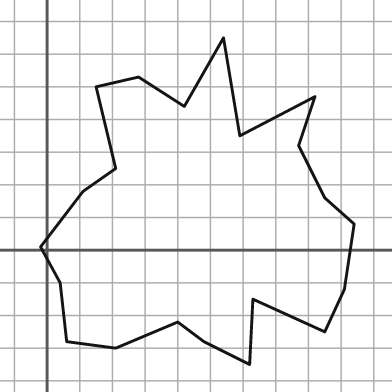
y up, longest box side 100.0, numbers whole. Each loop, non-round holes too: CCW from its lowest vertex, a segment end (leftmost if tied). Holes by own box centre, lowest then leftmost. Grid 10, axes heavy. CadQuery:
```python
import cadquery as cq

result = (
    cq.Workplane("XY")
    .moveTo(62.0, -35.0)
    .lineTo(63.0, -15.0)
    .lineTo(85.0, -25.0)
    .lineTo(91.0, -12.0)
    .lineTo(94.0, 8.0)
    .lineTo(85.0, 16.0)
    .lineTo(77.0, 32.0)
    .lineTo(82.0, 47.0)
    .lineTo(59.0, 35.0)
    .lineTo(54.0, 65.0)
    .lineTo(42.0, 44.0)
    .lineTo(28.0, 53.0)
    .lineTo(15.0, 50.0)
    .lineTo(21.0, 25.0)
    .lineTo(11.0, 18.0)
    .lineTo(-2.0, 1.0)
    .lineTo(4.0, -10.0)
    .lineTo(6.0, -28.0)
    .lineTo(21.0, -30.0)
    .lineTo(40.0, -22.0)
    .lineTo(48.0, -28.0)
    .close()
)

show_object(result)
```